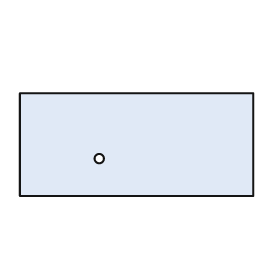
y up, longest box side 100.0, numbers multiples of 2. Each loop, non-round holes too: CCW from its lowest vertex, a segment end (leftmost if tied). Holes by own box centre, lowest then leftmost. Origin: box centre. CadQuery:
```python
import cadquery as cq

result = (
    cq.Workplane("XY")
    .moveTo(-50.0, -22.0)
    .lineTo(50.0, -22.0)
    .lineTo(50.0, 22.0)
    .lineTo(-50.0, 22.0)
    .close()
    .moveTo(-16.0, -6.0)
    .circle(2.0)
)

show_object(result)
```